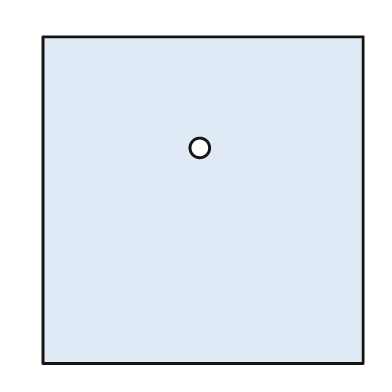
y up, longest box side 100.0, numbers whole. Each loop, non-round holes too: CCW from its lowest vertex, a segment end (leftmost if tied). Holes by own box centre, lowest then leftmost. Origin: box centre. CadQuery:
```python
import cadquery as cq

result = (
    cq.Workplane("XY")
    .moveTo(-49.0, -50.0)
    .lineTo(49.0, -50.0)
    .lineTo(49.0, 50.0)
    .lineTo(-49.0, 50.0)
    .close()
    .moveTo(-1.0, 16.0)
    .circle(3.0)
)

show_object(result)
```